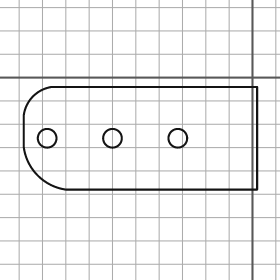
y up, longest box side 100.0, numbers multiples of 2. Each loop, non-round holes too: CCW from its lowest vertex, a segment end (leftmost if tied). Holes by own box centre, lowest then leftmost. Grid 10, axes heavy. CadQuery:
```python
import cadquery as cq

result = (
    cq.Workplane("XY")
    .moveTo(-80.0, -48.0)
    .lineTo(2.0, -48.0)
    .lineTo(2.0, -4.0)
    .lineTo(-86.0, -4.0)
    .threePointArc((-94.0, -8.0), (-98.0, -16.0))
    .lineTo(-98.0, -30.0)
    .threePointArc((-92.0, -42.0), (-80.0, -48.0))
    .close()
    .moveTo(-88.0, -26.0)
    .circle(4.0)
    .moveTo(-60.0, -26.0)
    .circle(4.0)
    .moveTo(-32.0, -26.0)
    .circle(4.0)
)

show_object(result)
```